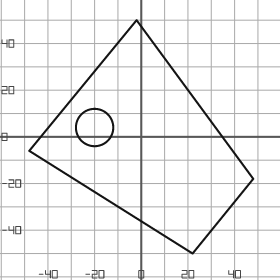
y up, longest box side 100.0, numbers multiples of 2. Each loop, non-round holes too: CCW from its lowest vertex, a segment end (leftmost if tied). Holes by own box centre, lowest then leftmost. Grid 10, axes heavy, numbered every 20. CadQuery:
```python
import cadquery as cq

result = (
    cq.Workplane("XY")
    .moveTo(22.0, -50.0)
    .lineTo(48.0, -18.0)
    .lineTo(-2.0, 50.0)
    .lineTo(-48.0, -6.0)
    .close()
    .moveTo(-20.0, 4.0)
    .circle(8.0)
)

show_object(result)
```